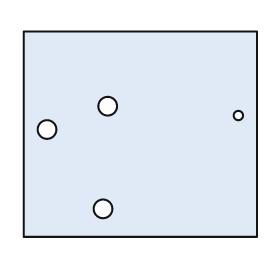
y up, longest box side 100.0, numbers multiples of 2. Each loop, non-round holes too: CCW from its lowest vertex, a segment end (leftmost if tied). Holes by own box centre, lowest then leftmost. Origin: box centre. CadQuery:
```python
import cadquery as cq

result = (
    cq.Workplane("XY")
    .moveTo(-50.0, -44.0)
    .lineTo(50.0, -44.0)
    .lineTo(50.0, 44.0)
    .lineTo(-50.0, 44.0)
    .close()
    .moveTo(-16.0, -32.0)
    .circle(4.0)
    .moveTo(-40.0, 2.0)
    .circle(4.0)
    .moveTo(42.0, 8.0)
    .circle(2.0)
    .moveTo(-14.0, 12.0)
    .circle(4.0)
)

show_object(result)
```